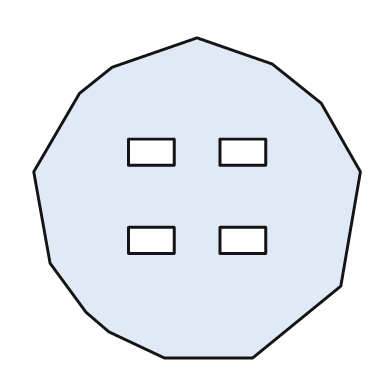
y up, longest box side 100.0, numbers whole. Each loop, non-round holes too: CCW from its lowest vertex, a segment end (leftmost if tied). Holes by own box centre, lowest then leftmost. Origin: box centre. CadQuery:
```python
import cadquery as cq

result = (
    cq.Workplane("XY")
    .moveTo(-10.0, -49.0)
    .lineTo(17.0, -49.0)
    .lineTo(44.0, -27.0)
    .lineTo(50.0, 8.0)
    .lineTo(38.0, 29.0)
    .lineTo(23.0, 41.0)
    .lineTo(0.0, 49.0)
    .lineTo(-26.0, 40.0)
    .lineTo(-36.0, 32.0)
    .lineTo(-50.0, 8.0)
    .lineTo(-45.0, -20.0)
    .lineTo(-34.0, -35.0)
    .lineTo(-27.0, -41.0)
    .close()
    .moveTo(-21.0, -17.0)
    .lineTo(-7.0, -17.0)
    .lineTo(-7.0, -9.0)
    .lineTo(-21.0, -9.0)
    .close()
    .moveTo(7.0, -17.0)
    .lineTo(21.0, -17.0)
    .lineTo(21.0, -9.0)
    .lineTo(7.0, -9.0)
    .close()
    .moveTo(-21.0, 10.0)
    .lineTo(-7.0, 10.0)
    .lineTo(-7.0, 18.0)
    .lineTo(-21.0, 18.0)
    .close()
    .moveTo(7.0, 10.0)
    .lineTo(21.0, 10.0)
    .lineTo(21.0, 18.0)
    .lineTo(7.0, 18.0)
    .close()
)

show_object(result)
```